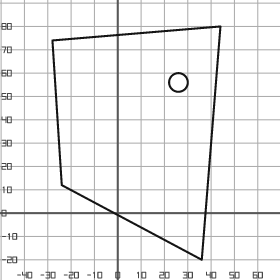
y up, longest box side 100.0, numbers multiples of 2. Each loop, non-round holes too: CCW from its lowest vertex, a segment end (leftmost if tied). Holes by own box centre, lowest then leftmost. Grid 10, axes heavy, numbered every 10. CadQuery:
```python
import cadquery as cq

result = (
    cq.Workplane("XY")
    .moveTo(36.0, -20.0)
    .lineTo(44.0, 80.0)
    .lineTo(-28.0, 74.0)
    .lineTo(-24.0, 12.0)
    .close()
    .moveTo(26.0, 56.0)
    .circle(4.0)
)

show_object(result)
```